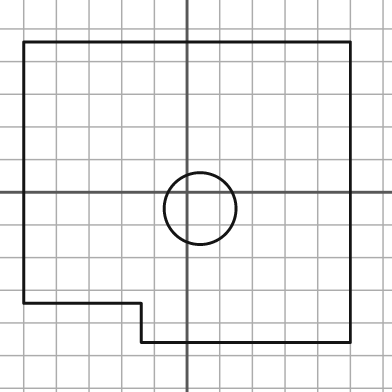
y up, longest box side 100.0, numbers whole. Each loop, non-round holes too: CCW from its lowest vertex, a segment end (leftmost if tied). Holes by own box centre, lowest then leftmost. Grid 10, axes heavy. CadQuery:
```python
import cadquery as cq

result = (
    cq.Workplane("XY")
    .moveTo(-14.0, -46.0)
    .lineTo(50.0, -46.0)
    .lineTo(50.0, 46.0)
    .lineTo(-50.0, 46.0)
    .lineTo(-50.0, -34.0)
    .lineTo(-14.0, -34.0)
    .close()
    .moveTo(4.0, -5.0)
    .circle(11.0)
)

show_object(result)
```